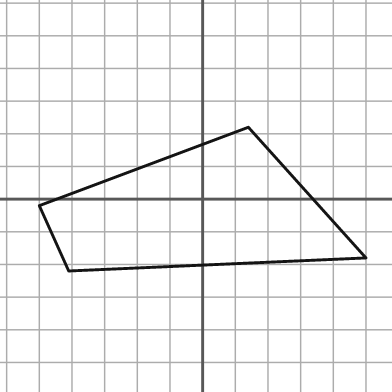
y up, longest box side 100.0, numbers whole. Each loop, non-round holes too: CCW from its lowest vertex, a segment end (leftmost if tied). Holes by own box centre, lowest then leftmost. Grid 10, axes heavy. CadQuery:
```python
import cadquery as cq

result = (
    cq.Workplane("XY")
    .moveTo(-41.0, -22.0)
    .lineTo(50.0, -18.0)
    .lineTo(14.0, 22.0)
    .lineTo(-50.0, -2.0)
    .close()
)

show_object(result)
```